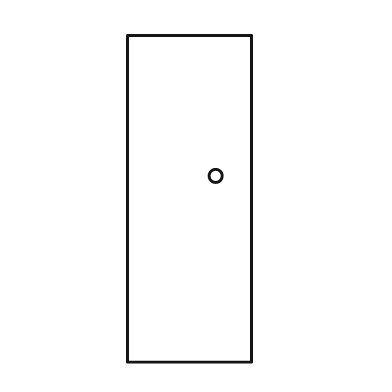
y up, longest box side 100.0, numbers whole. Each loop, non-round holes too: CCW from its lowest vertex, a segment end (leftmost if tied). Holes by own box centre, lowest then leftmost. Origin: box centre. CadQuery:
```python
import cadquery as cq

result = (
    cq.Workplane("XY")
    .moveTo(-19.0, -50.0)
    .lineTo(19.0, -50.0)
    .lineTo(19.0, 50.0)
    .lineTo(-19.0, 50.0)
    .close()
    .moveTo(8.0, 7.0)
    .circle(2.0)
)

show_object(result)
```